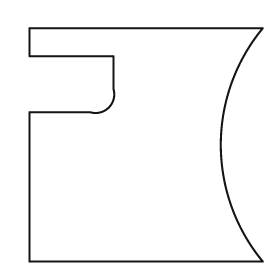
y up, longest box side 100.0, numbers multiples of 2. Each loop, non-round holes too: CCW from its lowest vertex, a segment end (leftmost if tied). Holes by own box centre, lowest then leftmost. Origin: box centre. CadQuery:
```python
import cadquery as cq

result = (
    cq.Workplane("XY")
    .moveTo(-50.0, -50.0)
    .lineTo(50.0, -50.0)
    .threePointArc((32.0, 0.0), (50.0, 50.0))
    .lineTo(-50.0, 50.0)
    .lineTo(-50.0, 38.0)
    .lineTo(-14.0, 38.0)
    .lineTo(-14.0, 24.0)
    .threePointArc((-16.0, 16.0), (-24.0, 14.0))
    .lineTo(-50.0, 14.0)
    .close()
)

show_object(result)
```